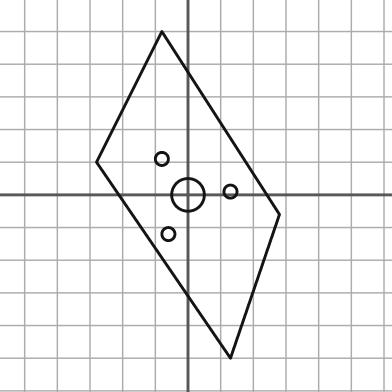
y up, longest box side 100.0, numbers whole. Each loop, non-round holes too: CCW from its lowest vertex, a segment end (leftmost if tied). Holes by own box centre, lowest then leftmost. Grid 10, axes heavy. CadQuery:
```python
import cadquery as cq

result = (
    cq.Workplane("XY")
    .moveTo(13.0, -50.0)
    .lineTo(28.0, -6.0)
    .lineTo(-8.0, 50.0)
    .lineTo(-28.0, 10.0)
    .close()
    .moveTo(-6.0, -12.0)
    .circle(2.0)
    .moveTo(0.0, 0.0)
    .circle(5.0)
    .moveTo(13.0, 1.0)
    .circle(2.0)
    .moveTo(-8.0, 11.0)
    .circle(2.0)
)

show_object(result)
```